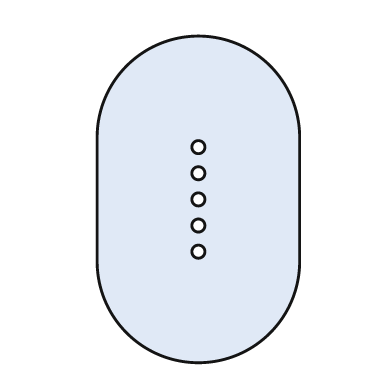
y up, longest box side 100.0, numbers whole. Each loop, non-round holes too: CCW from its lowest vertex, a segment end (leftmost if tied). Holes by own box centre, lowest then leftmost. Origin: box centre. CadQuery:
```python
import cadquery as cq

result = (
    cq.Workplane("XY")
    .moveTo(-31.0, -19.0)
    .threePointArc((0.0, -50.0), (31.0, -19.0))
    .lineTo(31.0, 19.0)
    .threePointArc((0.0, 50.0), (-31.0, 19.0))
    .close()
    .moveTo(0.0, -16.0)
    .circle(2.0)
    .moveTo(0.0, -8.0)
    .circle(2.0)
    .moveTo(0.0, 0.0)
    .circle(2.0)
    .moveTo(0.0, 8.0)
    .circle(2.0)
    .moveTo(0.0, 16.0)
    .circle(2.0)
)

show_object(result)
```